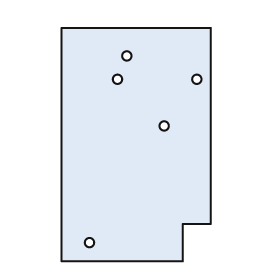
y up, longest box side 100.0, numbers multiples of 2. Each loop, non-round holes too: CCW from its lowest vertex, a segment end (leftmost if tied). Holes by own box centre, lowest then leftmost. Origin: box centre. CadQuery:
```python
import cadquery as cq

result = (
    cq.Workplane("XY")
    .moveTo(-32.0, -50.0)
    .lineTo(20.0, -50.0)
    .lineTo(20.0, -34.0)
    .lineTo(32.0, -34.0)
    .lineTo(32.0, 50.0)
    .lineTo(-32.0, 50.0)
    .close()
    .moveTo(-20.0, -42.0)
    .circle(2.0)
    .moveTo(12.0, 8.0)
    .circle(2.0)
    .moveTo(-8.0, 28.0)
    .circle(2.0)
    .moveTo(26.0, 28.0)
    .circle(2.0)
    .moveTo(-4.0, 38.0)
    .circle(2.0)
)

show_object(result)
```